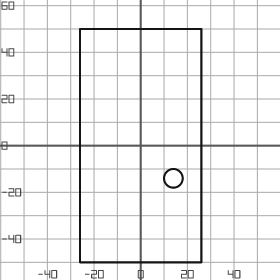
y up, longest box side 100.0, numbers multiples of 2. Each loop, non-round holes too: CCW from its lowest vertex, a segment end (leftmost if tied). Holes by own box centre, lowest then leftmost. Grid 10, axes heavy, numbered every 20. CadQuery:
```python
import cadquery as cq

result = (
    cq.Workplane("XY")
    .moveTo(-26.0, -50.0)
    .lineTo(26.0, -50.0)
    .lineTo(26.0, 50.0)
    .lineTo(-26.0, 50.0)
    .close()
    .moveTo(14.0, -14.0)
    .circle(4.0)
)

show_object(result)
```